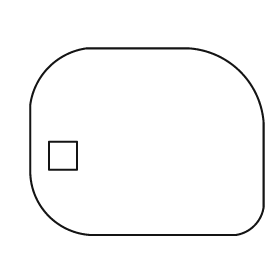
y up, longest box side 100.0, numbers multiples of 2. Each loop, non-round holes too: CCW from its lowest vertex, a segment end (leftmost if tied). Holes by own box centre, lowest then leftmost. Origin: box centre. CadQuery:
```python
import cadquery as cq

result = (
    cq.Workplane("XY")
    .moveTo(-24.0, -40.0)
    .lineTo(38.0, -40.0)
    .threePointArc((46.0, -36.0), (50.0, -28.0))
    .lineTo(50.0, 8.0)
    .threePointArc((40.0, 30.0), (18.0, 40.0))
    .lineTo(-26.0, 40.0)
    .threePointArc((-42.0, 32.0), (-50.0, 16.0))
    .lineTo(-50.0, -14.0)
    .threePointArc((-42.0, -32.0), (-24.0, -40.0))
    .close()
    .moveTo(-42.0, -12.0)
    .lineTo(-30.0, -12.0)
    .lineTo(-30.0, 0.0)
    .lineTo(-42.0, 0.0)
    .close()
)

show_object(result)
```